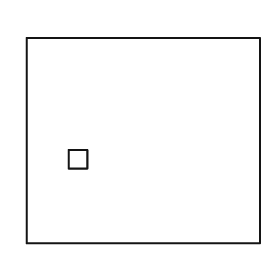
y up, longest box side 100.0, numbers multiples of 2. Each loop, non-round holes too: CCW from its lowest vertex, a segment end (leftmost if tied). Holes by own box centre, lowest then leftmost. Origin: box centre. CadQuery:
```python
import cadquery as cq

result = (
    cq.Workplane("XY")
    .moveTo(-50.0, -44.0)
    .lineTo(50.0, -44.0)
    .lineTo(50.0, 44.0)
    .lineTo(-50.0, 44.0)
    .close()
    .moveTo(-32.0, -12.0)
    .lineTo(-24.0, -12.0)
    .lineTo(-24.0, -4.0)
    .lineTo(-32.0, -4.0)
    .close()
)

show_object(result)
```